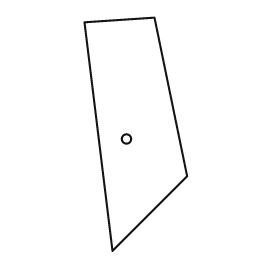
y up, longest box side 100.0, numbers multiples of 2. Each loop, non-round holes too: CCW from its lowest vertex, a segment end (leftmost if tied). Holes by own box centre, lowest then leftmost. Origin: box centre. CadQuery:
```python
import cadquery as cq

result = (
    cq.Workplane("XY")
    .moveTo(-10.0, -50.0)
    .lineTo(22.0, -18.0)
    .lineTo(8.0, 50.0)
    .lineTo(-22.0, 48.0)
    .close()
    .moveTo(-4.0, -2.0)
    .circle(2.0)
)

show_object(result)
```